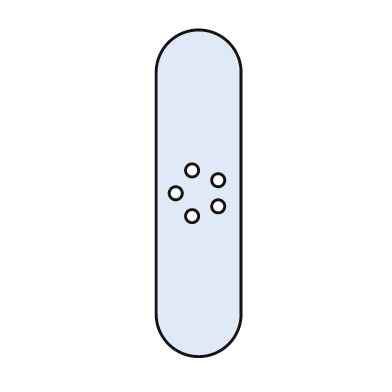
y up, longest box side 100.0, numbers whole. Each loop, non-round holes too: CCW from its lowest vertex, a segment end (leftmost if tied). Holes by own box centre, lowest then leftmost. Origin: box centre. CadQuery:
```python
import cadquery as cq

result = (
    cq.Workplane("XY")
    .moveTo(-13.0, -37.0)
    .threePointArc((0.0, -50.0), (13.0, -37.0))
    .lineTo(13.0, 37.0)
    .threePointArc((0.0, 50.0), (-13.0, 37.0))
    .close()
    .moveTo(-2.0, -7.0)
    .circle(2.0)
    .moveTo(6.0, -4.0)
    .circle(2.0)
    .moveTo(-7.0, 0.0)
    .circle(2.0)
    .moveTo(6.0, 4.0)
    .circle(2.0)
    .moveTo(-2.0, 7.0)
    .circle(2.0)
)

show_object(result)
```